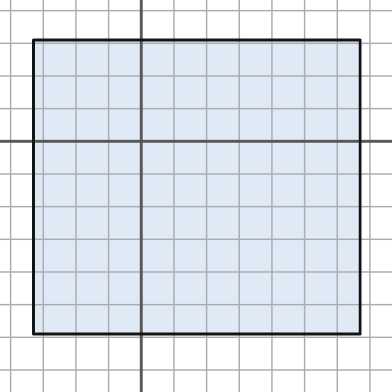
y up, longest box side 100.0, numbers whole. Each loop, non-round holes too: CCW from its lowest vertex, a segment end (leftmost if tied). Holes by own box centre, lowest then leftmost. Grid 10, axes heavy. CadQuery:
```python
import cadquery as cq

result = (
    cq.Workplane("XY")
    .moveTo(-33.0, -59.0)
    .lineTo(67.0, -59.0)
    .lineTo(67.0, 31.0)
    .lineTo(-33.0, 31.0)
    .close()
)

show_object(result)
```